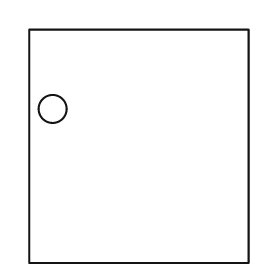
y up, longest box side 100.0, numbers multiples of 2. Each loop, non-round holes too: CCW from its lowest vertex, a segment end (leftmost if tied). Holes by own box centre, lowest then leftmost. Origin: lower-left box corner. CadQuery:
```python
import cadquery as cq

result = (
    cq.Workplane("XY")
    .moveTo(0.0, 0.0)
    .lineTo(94.0, 0.0)
    .lineTo(94.0, 100.0)
    .lineTo(0.0, 100.0)
    .close()
    .moveTo(10.0, 66.0)
    .circle(6.0)
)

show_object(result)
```